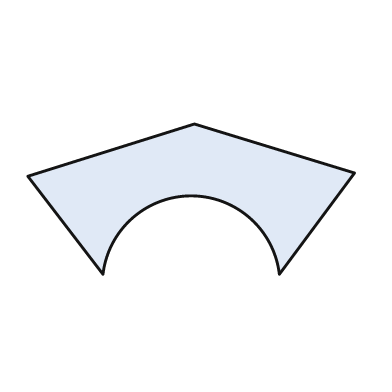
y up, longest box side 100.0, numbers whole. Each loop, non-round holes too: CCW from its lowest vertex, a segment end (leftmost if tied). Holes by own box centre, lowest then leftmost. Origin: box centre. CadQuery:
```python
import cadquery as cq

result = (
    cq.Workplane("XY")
    .moveTo(-27.0, -23.0)
    .threePointArc((0.0, 1.0), (27.0, -23.0))
    .lineTo(50.0, 8.0)
    .lineTo(1.0, 23.0)
    .lineTo(-50.0, 7.0)
    .close()
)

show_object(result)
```